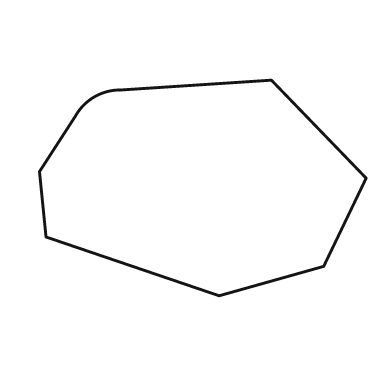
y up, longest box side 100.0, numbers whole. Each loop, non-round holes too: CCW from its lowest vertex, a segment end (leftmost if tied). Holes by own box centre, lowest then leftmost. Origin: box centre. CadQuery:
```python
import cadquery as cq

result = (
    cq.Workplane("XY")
    .moveTo(5.0, -33.0)
    .lineTo(37.0, -24.0)
    .lineTo(50.0, 3.0)
    .lineTo(21.0, 33.0)
    .lineTo(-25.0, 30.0)
    .threePointArc((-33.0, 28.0), (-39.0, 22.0))
    .lineTo(-50.0, 5.0)
    .lineTo(-48.0, -15.0)
    .close()
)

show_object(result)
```